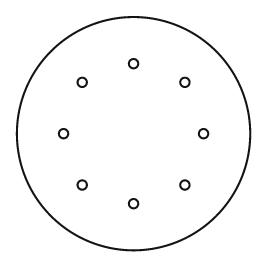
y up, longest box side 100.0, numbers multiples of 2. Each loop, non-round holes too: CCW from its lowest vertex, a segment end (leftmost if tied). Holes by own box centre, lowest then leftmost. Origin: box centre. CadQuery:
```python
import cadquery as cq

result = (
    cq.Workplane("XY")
    .moveTo(0.0, 0.0)
    .circle(50.0)
    .moveTo(0.0, -30.0)
    .circle(2.0)
    .moveTo(-22.0, -22.0)
    .circle(2.0)
    .moveTo(22.0, -22.0)
    .circle(2.0)
    .moveTo(-30.0, 0.0)
    .circle(2.0)
    .moveTo(30.0, 0.0)
    .circle(2.0)
    .moveTo(-22.0, 22.0)
    .circle(2.0)
    .moveTo(22.0, 22.0)
    .circle(2.0)
    .moveTo(0.0, 30.0)
    .circle(2.0)
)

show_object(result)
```